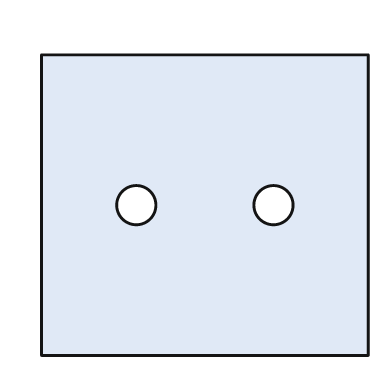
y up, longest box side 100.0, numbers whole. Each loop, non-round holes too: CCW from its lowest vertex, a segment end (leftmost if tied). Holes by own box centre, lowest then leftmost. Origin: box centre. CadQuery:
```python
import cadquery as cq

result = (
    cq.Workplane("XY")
    .moveTo(-50.0, -46.0)
    .lineTo(50.0, -46.0)
    .lineTo(50.0, 46.0)
    .lineTo(-50.0, 46.0)
    .close()
    .moveTo(-21.0, 0.0)
    .circle(6.0)
    .moveTo(21.0, 0.0)
    .circle(6.0)
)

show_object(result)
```